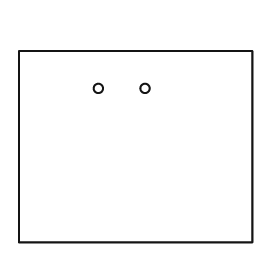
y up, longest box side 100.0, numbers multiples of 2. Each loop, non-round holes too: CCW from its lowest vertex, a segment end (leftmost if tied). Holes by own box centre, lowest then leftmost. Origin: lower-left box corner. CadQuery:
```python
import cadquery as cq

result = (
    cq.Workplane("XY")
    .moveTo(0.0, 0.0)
    .lineTo(100.0, 0.0)
    .lineTo(100.0, 82.0)
    .lineTo(0.0, 82.0)
    .close()
    .moveTo(34.0, 66.0)
    .circle(2.0)
    .moveTo(54.0, 66.0)
    .circle(2.0)
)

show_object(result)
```